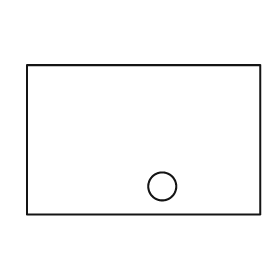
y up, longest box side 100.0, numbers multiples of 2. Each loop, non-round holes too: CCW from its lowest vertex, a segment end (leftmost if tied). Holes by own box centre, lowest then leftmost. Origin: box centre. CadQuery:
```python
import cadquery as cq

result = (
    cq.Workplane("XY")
    .moveTo(-50.0, -32.0)
    .lineTo(50.0, -32.0)
    .lineTo(50.0, 32.0)
    .lineTo(-50.0, 32.0)
    .close()
    .moveTo(8.0, -20.0)
    .circle(6.0)
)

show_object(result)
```